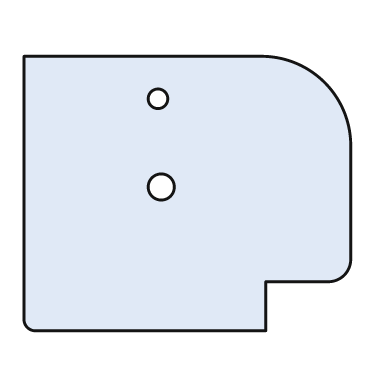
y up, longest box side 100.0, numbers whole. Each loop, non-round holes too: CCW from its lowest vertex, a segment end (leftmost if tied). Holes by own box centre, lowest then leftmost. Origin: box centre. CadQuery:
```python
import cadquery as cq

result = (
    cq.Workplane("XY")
    .moveTo(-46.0, -42.0)
    .lineTo(24.0, -42.0)
    .lineTo(24.0, -27.0)
    .lineTo(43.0, -27.0)
    .threePointArc((48.0, -25.0), (50.0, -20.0))
    .lineTo(50.0, 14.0)
    .threePointArc((42.0, 34.0), (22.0, 42.0))
    .lineTo(-50.0, 42.0)
    .lineTo(-50.0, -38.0)
    .threePointArc((-49.0, -41.0), (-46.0, -42.0))
    .close()
    .moveTo(-8.0, 2.0)
    .circle(4.0)
    .moveTo(-9.0, 29.0)
    .circle(3.0)
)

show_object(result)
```